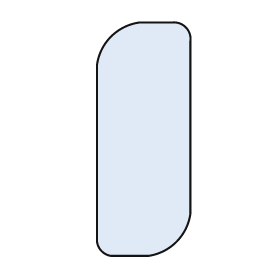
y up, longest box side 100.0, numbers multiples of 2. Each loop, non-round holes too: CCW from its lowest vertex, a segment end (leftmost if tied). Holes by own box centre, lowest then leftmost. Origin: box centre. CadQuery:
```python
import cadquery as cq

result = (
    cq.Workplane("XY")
    .moveTo(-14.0, -50.0)
    .lineTo(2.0, -50.0)
    .threePointArc((14.0, -44.0), (20.0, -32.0))
    .lineTo(20.0, 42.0)
    .threePointArc((18.0, 48.0), (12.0, 50.0))
    .lineTo(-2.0, 50.0)
    .threePointArc((-14.0, 44.0), (-20.0, 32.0))
    .lineTo(-20.0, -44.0)
    .threePointArc((-18.0, -48.0), (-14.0, -50.0))
    .close()
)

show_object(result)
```